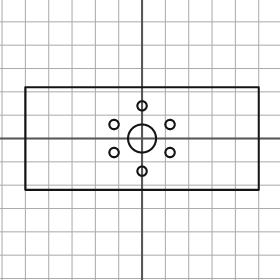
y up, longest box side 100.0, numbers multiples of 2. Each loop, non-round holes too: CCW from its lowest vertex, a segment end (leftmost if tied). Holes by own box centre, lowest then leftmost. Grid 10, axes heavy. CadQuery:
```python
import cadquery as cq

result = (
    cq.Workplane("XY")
    .moveTo(-50.0, -22.0)
    .lineTo(50.0, -22.0)
    .lineTo(50.0, 22.0)
    .lineTo(-50.0, 22.0)
    .close()
    .moveTo(0.0, -14.0)
    .circle(2.0)
    .moveTo(-12.0, -6.0)
    .circle(2.0)
    .moveTo(12.0, -6.0)
    .circle(2.0)
    .moveTo(0.0, 0.0)
    .circle(6.0)
    .moveTo(-12.0, 6.0)
    .circle(2.0)
    .moveTo(12.0, 6.0)
    .circle(2.0)
    .moveTo(0.0, 14.0)
    .circle(2.0)
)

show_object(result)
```